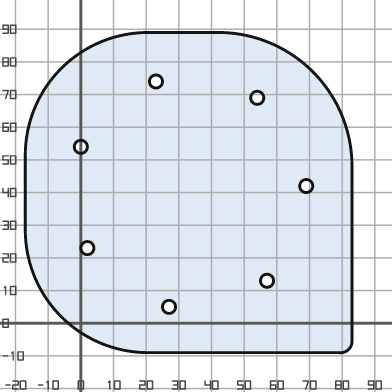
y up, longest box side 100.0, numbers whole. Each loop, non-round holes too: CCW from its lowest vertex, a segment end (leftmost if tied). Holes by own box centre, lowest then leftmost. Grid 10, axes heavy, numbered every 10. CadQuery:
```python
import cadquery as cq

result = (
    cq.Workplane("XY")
    .moveTo(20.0, -9.0)
    .lineTo(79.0, -9.0)
    .threePointArc((82.0, -8.0), (83.0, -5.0))
    .lineTo(83.0, 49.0)
    .threePointArc((71.0, 77.0), (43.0, 89.0))
    .lineTo(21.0, 89.0)
    .threePointArc((-6.0, 78.0), (-17.0, 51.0))
    .lineTo(-17.0, 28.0)
    .threePointArc((-6.0, 2.0), (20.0, -9.0))
    .close()
    .moveTo(27.0, 5.0)
    .circle(2.0)
    .moveTo(57.0, 13.0)
    .circle(2.0)
    .moveTo(2.0, 23.0)
    .circle(2.0)
    .moveTo(69.0, 42.0)
    .circle(2.0)
    .moveTo(0.0, 54.0)
    .circle(2.0)
    .moveTo(54.0, 69.0)
    .circle(2.0)
    .moveTo(23.0, 74.0)
    .circle(2.0)
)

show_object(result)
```